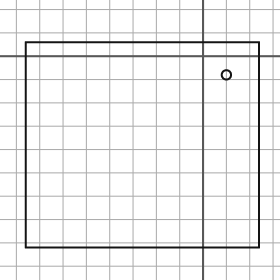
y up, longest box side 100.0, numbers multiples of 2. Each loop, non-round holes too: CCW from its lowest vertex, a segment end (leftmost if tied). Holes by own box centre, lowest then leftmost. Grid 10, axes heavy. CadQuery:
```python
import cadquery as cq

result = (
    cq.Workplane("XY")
    .moveTo(-76.0, -82.0)
    .lineTo(24.0, -82.0)
    .lineTo(24.0, 6.0)
    .lineTo(-76.0, 6.0)
    .close()
    .moveTo(10.0, -8.0)
    .circle(2.0)
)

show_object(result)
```